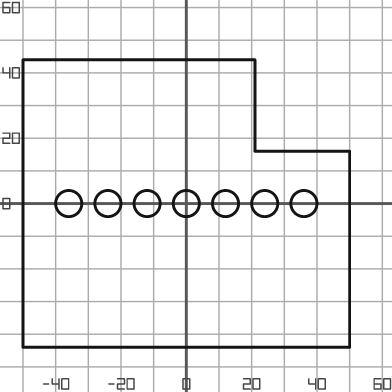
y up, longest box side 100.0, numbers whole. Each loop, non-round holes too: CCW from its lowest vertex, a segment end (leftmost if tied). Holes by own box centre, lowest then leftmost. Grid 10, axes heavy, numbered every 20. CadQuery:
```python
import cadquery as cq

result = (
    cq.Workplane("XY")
    .moveTo(-50.0, -44.0)
    .lineTo(50.0, -44.0)
    .lineTo(50.0, 16.0)
    .lineTo(21.0, 16.0)
    .lineTo(21.0, 44.0)
    .lineTo(-50.0, 44.0)
    .close()
    .moveTo(-36.0, 0.0)
    .circle(4.0)
    .moveTo(-24.0, 0.0)
    .circle(4.0)
    .moveTo(-12.0, 0.0)
    .circle(4.0)
    .moveTo(0.0, 0.0)
    .circle(4.0)
    .moveTo(12.0, 0.0)
    .circle(4.0)
    .moveTo(24.0, 0.0)
    .circle(4.0)
    .moveTo(36.0, 0.0)
    .circle(4.0)
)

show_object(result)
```